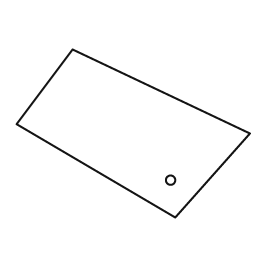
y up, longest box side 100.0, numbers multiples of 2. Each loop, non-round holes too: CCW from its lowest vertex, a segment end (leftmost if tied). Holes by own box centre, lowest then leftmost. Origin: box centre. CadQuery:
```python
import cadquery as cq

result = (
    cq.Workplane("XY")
    .moveTo(18.0, -36.0)
    .lineTo(50.0, 0.0)
    .lineTo(-26.0, 36.0)
    .lineTo(-50.0, 4.0)
    .close()
    .moveTo(16.0, -20.0)
    .circle(2.0)
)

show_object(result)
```